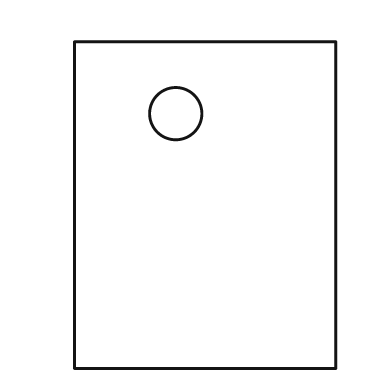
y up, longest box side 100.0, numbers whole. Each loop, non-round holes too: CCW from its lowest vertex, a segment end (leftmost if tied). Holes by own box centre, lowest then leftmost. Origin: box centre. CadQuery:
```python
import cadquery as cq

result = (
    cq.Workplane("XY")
    .moveTo(-40.0, -50.0)
    .lineTo(40.0, -50.0)
    .lineTo(40.0, 50.0)
    .lineTo(-40.0, 50.0)
    .close()
    .moveTo(-9.0, 28.0)
    .circle(8.0)
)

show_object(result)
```